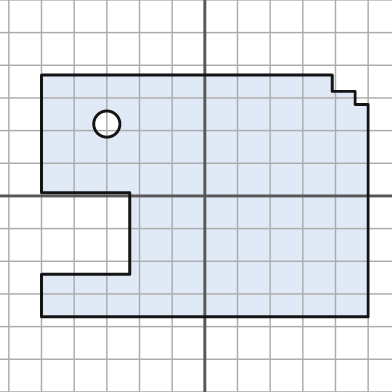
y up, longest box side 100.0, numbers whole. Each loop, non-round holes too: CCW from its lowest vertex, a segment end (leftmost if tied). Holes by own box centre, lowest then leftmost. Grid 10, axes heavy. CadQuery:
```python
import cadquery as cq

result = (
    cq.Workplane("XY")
    .moveTo(-50.0, -37.0)
    .lineTo(50.0, -37.0)
    .lineTo(50.0, 28.0)
    .lineTo(46.0, 28.0)
    .lineTo(46.0, 32.0)
    .lineTo(39.0, 32.0)
    .lineTo(39.0, 37.0)
    .lineTo(-50.0, 37.0)
    .lineTo(-50.0, 1.0)
    .lineTo(-23.0, 1.0)
    .lineTo(-23.0, -24.0)
    .lineTo(-50.0, -24.0)
    .close()
    .moveTo(-30.0, 22.0)
    .circle(4.0)
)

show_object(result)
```